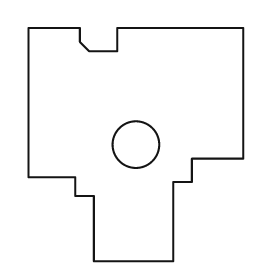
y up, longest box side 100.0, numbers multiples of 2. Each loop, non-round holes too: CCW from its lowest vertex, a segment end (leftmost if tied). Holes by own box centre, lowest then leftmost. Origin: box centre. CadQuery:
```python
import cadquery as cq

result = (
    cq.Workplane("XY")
    .moveTo(-18.0, -50.0)
    .lineTo(16.0, -50.0)
    .lineTo(16.0, -16.0)
    .lineTo(24.0, -16.0)
    .lineTo(24.0, -6.0)
    .lineTo(46.0, -6.0)
    .lineTo(46.0, 50.0)
    .lineTo(-8.0, 50.0)
    .lineTo(-8.0, 40.0)
    .lineTo(-20.0, 40.0)
    .lineTo(-24.0, 44.0)
    .lineTo(-24.0, 50.0)
    .lineTo(-46.0, 50.0)
    .lineTo(-46.0, -14.0)
    .lineTo(-26.0, -14.0)
    .lineTo(-26.0, -22.0)
    .lineTo(-18.0, -22.0)
    .close()
    .moveTo(0.0, 0.0)
    .circle(10.0)
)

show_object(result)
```